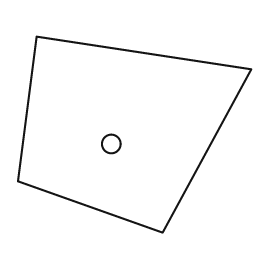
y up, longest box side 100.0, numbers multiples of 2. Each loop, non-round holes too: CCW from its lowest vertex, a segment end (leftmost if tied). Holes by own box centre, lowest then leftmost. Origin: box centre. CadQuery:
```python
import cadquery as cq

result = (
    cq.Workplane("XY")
    .moveTo(12.0, -42.0)
    .lineTo(50.0, 28.0)
    .lineTo(-42.0, 42.0)
    .lineTo(-50.0, -20.0)
    .close()
    .moveTo(-10.0, -4.0)
    .circle(4.0)
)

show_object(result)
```